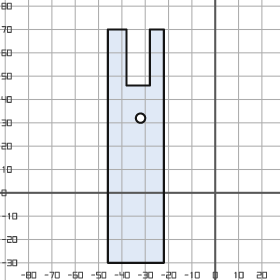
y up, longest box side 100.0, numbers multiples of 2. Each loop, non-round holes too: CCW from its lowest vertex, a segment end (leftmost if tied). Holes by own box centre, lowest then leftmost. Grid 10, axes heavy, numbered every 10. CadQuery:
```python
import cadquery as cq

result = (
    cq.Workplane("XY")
    .moveTo(-46.0, -30.0)
    .lineTo(-22.0, -30.0)
    .lineTo(-22.0, 70.0)
    .lineTo(-28.0, 70.0)
    .lineTo(-28.0, 46.0)
    .lineTo(-38.0, 46.0)
    .lineTo(-38.0, 70.0)
    .lineTo(-46.0, 70.0)
    .close()
    .moveTo(-32.0, 32.0)
    .circle(2.0)
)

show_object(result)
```